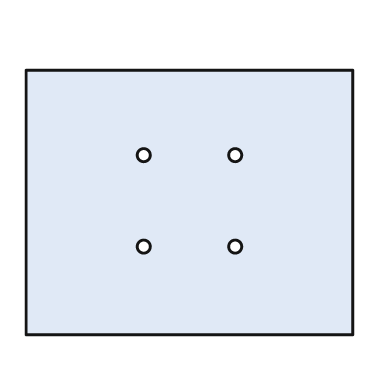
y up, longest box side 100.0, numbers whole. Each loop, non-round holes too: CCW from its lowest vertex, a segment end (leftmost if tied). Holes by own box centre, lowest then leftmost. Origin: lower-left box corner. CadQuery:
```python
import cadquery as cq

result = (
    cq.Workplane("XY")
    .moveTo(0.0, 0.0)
    .lineTo(100.0, 0.0)
    .lineTo(100.0, 81.0)
    .lineTo(0.0, 81.0)
    .close()
    .moveTo(36.0, 27.0)
    .circle(2.0)
    .moveTo(64.0, 27.0)
    .circle(2.0)
    .moveTo(36.0, 55.0)
    .circle(2.0)
    .moveTo(64.0, 55.0)
    .circle(2.0)
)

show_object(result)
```